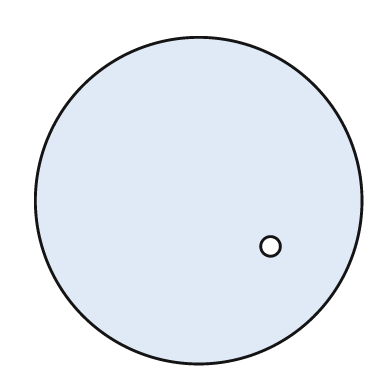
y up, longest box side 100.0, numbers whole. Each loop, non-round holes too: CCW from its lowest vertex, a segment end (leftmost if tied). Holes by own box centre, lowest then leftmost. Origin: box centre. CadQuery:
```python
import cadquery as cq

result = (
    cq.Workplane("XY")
    .moveTo(0.0, 0.0)
    .circle(50.0)
    .moveTo(22.0, -14.0)
    .circle(3.0)
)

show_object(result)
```